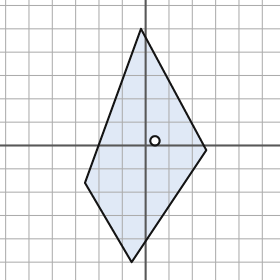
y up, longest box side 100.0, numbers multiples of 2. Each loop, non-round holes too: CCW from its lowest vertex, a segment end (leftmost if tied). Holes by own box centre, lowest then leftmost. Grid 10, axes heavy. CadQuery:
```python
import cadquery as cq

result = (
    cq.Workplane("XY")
    .moveTo(-6.0, -50.0)
    .lineTo(26.0, -2.0)
    .lineTo(-2.0, 50.0)
    .lineTo(-26.0, -16.0)
    .close()
    .moveTo(4.0, 2.0)
    .circle(2.0)
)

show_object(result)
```